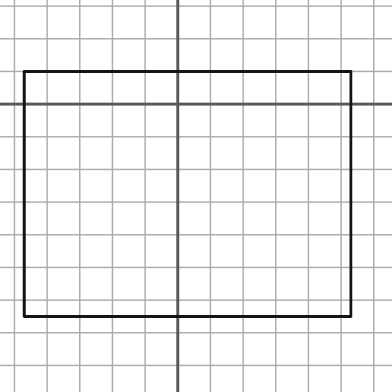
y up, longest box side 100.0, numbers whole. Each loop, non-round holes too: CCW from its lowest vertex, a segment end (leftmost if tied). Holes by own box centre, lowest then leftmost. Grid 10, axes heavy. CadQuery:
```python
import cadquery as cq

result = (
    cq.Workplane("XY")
    .moveTo(-47.0, -65.0)
    .lineTo(53.0, -65.0)
    .lineTo(53.0, 10.0)
    .lineTo(-47.0, 10.0)
    .close()
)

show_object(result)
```